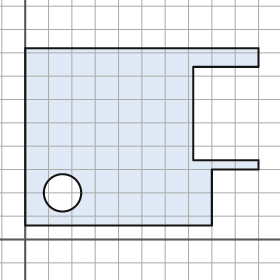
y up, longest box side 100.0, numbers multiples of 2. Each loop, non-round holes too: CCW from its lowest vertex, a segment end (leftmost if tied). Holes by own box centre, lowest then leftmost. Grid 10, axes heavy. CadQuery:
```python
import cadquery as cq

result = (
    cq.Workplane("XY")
    .moveTo(0.0, 6.0)
    .lineTo(80.0, 6.0)
    .lineTo(80.0, 30.0)
    .lineTo(100.0, 30.0)
    .lineTo(100.0, 34.0)
    .lineTo(72.0, 34.0)
    .lineTo(72.0, 74.0)
    .lineTo(100.0, 74.0)
    .lineTo(100.0, 82.0)
    .lineTo(0.0, 82.0)
    .close()
    .moveTo(16.0, 20.0)
    .circle(8.0)
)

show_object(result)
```